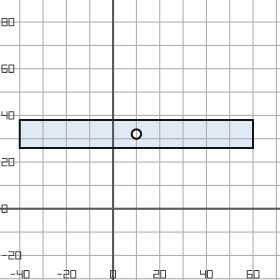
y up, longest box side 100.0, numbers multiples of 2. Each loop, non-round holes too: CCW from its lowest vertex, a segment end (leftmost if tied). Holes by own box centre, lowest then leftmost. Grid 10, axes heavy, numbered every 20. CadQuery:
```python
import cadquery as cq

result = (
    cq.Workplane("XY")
    .moveTo(-40.0, 26.0)
    .lineTo(60.0, 26.0)
    .lineTo(60.0, 38.0)
    .lineTo(-40.0, 38.0)
    .close()
    .moveTo(10.0, 32.0)
    .circle(2.0)
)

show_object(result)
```